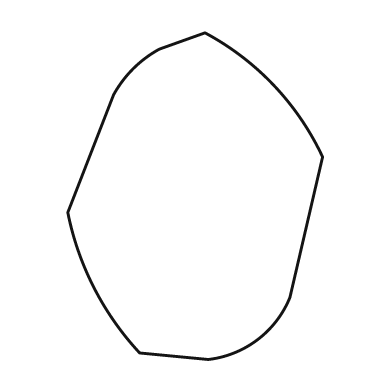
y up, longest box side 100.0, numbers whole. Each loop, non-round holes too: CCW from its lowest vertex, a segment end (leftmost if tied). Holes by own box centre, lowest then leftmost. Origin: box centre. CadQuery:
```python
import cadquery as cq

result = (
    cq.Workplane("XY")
    .moveTo(4.0, -50.0)
    .threePointArc((19.0, -44.0), (29.0, -31.0))
    .lineTo(39.0, 12.0)
    .threePointArc((24.0, 34.0), (3.0, 50.0))
    .lineTo(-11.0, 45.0)
    .threePointArc((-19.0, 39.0), (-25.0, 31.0))
    .lineTo(-39.0, -5.0)
    .threePointArc((-31.0, -28.0), (-17.0, -48.0))
    .close()
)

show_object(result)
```